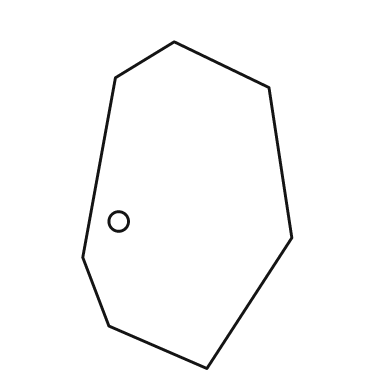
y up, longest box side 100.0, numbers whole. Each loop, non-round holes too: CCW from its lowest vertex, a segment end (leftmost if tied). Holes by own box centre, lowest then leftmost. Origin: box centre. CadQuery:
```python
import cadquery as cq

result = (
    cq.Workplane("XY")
    .moveTo(6.0, -50.0)
    .lineTo(32.0, -10.0)
    .lineTo(25.0, 36.0)
    .lineTo(-4.0, 50.0)
    .lineTo(-22.0, 39.0)
    .lineTo(-32.0, -16.0)
    .lineTo(-24.0, -37.0)
    .close()
    .moveTo(-21.0, -5.0)
    .circle(3.0)
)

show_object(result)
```